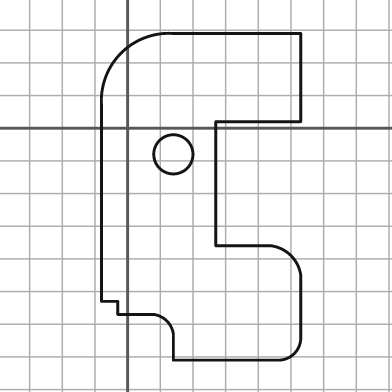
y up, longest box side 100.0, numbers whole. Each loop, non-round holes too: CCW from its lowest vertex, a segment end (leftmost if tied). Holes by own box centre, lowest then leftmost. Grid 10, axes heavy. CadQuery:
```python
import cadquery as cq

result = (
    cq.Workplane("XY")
    .moveTo(14.0, -71.0)
    .lineTo(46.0, -71.0)
    .threePointArc((51.0, -69.0), (53.0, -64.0))
    .lineTo(53.0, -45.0)
    .threePointArc((50.0, -39.0), (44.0, -36.0))
    .lineTo(27.0, -36.0)
    .lineTo(27.0, 2.0)
    .lineTo(53.0, 2.0)
    .lineTo(53.0, 29.0)
    .lineTo(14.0, 29.0)
    .threePointArc((-2.0, 23.0), (-8.0, 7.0))
    .lineTo(-8.0, -53.0)
    .lineTo(-3.0, -53.0)
    .lineTo(-3.0, -57.0)
    .lineTo(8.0, -57.0)
    .threePointArc((12.0, -59.0), (14.0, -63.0))
    .close()
    .moveTo(14.0, -8.0)
    .circle(6.0)
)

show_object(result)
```